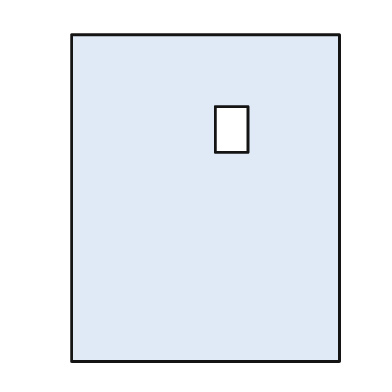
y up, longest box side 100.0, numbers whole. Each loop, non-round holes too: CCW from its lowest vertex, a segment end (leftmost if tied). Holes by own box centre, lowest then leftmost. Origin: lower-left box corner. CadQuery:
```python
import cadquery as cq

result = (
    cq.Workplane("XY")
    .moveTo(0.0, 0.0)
    .lineTo(82.0, 0.0)
    .lineTo(82.0, 100.0)
    .lineTo(0.0, 100.0)
    .close()
    .moveTo(44.0, 64.0)
    .lineTo(54.0, 64.0)
    .lineTo(54.0, 78.0)
    .lineTo(44.0, 78.0)
    .close()
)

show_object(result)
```